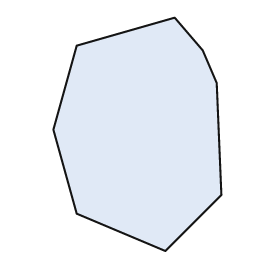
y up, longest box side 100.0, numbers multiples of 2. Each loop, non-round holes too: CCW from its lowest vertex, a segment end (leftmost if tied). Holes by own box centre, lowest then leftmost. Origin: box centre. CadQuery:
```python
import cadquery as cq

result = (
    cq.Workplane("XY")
    .moveTo(12.0, -50.0)
    .lineTo(36.0, -26.0)
    .lineTo(34.0, 22.0)
    .lineTo(28.0, 36.0)
    .lineTo(16.0, 50.0)
    .lineTo(-26.0, 38.0)
    .lineTo(-36.0, 2.0)
    .lineTo(-26.0, -34.0)
    .close()
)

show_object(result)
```